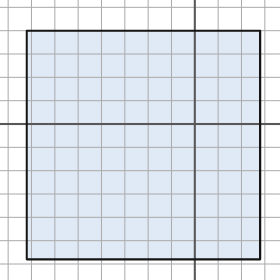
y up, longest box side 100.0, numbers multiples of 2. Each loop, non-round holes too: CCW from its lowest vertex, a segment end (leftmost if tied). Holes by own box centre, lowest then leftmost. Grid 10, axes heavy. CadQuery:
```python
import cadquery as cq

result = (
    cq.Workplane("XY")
    .moveTo(-72.0, -58.0)
    .lineTo(28.0, -58.0)
    .lineTo(28.0, 40.0)
    .lineTo(-72.0, 40.0)
    .close()
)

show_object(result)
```